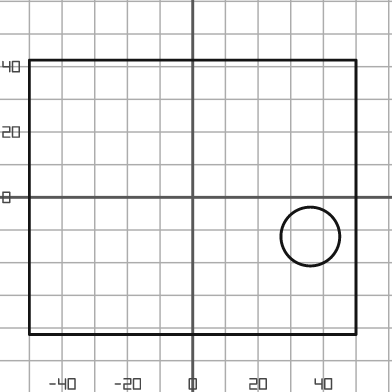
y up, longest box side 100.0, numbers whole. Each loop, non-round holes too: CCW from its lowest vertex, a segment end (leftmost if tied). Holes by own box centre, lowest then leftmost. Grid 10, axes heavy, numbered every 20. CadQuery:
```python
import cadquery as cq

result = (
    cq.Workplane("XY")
    .moveTo(-50.0, -42.0)
    .lineTo(50.0, -42.0)
    .lineTo(50.0, 42.0)
    .lineTo(-50.0, 42.0)
    .close()
    .moveTo(36.0, -12.0)
    .circle(9.0)
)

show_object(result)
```